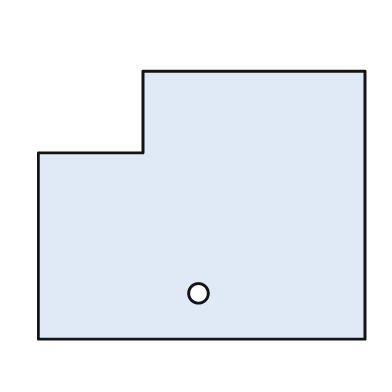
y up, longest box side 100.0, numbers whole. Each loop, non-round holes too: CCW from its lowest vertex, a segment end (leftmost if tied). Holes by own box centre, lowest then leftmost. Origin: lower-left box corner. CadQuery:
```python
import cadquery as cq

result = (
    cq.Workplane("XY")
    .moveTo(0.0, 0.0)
    .lineTo(100.0, 0.0)
    .lineTo(100.0, 82.0)
    .lineTo(32.0, 82.0)
    .lineTo(32.0, 57.0)
    .lineTo(0.0, 57.0)
    .close()
    .moveTo(49.0, 14.0)
    .circle(3.0)
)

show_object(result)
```